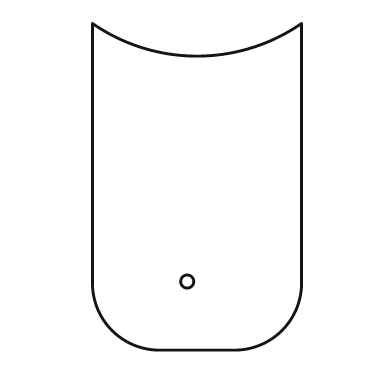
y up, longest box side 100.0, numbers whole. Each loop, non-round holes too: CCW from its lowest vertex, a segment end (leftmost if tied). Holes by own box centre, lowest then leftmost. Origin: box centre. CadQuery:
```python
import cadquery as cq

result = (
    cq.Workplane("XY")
    .moveTo(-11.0, -50.0)
    .lineTo(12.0, -50.0)
    .threePointArc((26.0, -44.0), (32.0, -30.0))
    .lineTo(32.0, 50.0)
    .threePointArc((0.0, 40.0), (-32.0, 50.0))
    .lineTo(-32.0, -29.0)
    .threePointArc((-26.0, -44.0), (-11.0, -50.0))
    .close()
    .moveTo(-3.0, -29.0)
    .circle(2.0)
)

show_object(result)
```